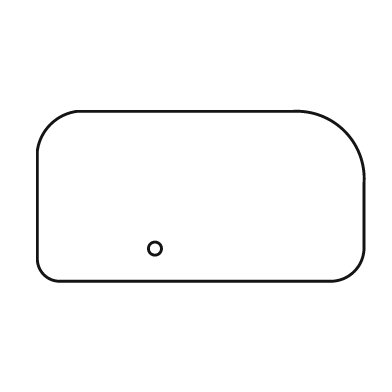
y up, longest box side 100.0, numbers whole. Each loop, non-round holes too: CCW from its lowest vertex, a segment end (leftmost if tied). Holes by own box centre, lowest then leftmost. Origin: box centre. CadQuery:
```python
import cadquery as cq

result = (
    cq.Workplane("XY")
    .moveTo(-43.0, -26.0)
    .lineTo(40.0, -26.0)
    .threePointArc((47.0, -23.0), (50.0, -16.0))
    .lineTo(50.0, 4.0)
    .threePointArc((44.0, 20.0), (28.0, 26.0))
    .lineTo(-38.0, 26.0)
    .threePointArc((-46.0, 22.0), (-50.0, 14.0))
    .lineTo(-50.0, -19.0)
    .threePointArc((-48.0, -24.0), (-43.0, -26.0))
    .close()
    .moveTo(-14.0, -16.0)
    .circle(2.0)
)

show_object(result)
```